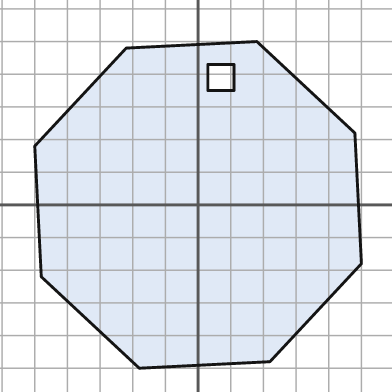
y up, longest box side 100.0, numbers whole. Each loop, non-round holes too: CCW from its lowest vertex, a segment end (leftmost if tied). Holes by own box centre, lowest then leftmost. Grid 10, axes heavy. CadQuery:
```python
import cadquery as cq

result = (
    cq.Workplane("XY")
    .moveTo(-18.0, -50.0)
    .lineTo(22.0, -48.0)
    .lineTo(50.0, -18.0)
    .lineTo(48.0, 22.0)
    .lineTo(18.0, 50.0)
    .lineTo(-22.0, 48.0)
    .lineTo(-50.0, 18.0)
    .lineTo(-48.0, -22.0)
    .close()
    .moveTo(3.0, 35.0)
    .lineTo(11.0, 35.0)
    .lineTo(11.0, 43.0)
    .lineTo(3.0, 43.0)
    .close()
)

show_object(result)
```